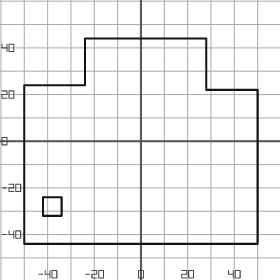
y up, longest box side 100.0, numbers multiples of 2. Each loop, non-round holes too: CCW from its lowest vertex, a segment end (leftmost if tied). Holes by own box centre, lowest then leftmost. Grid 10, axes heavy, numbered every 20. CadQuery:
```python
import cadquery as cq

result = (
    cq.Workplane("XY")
    .moveTo(-50.0, -44.0)
    .lineTo(50.0, -44.0)
    .lineTo(50.0, 22.0)
    .lineTo(28.0, 22.0)
    .lineTo(28.0, 44.0)
    .lineTo(-24.0, 44.0)
    .lineTo(-24.0, 24.0)
    .lineTo(-50.0, 24.0)
    .close()
    .moveTo(-42.0, -32.0)
    .lineTo(-34.0, -32.0)
    .lineTo(-34.0, -24.0)
    .lineTo(-42.0, -24.0)
    .close()
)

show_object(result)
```